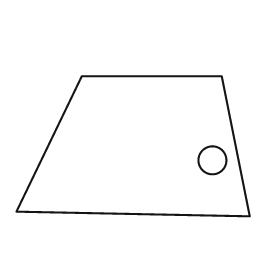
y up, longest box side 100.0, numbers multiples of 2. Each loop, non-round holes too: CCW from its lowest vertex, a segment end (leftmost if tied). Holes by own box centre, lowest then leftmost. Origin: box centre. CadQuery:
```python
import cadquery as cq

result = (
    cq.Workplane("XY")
    .moveTo(50.0, -30.0)
    .lineTo(38.0, 30.0)
    .lineTo(-22.0, 30.0)
    .lineTo(-50.0, -28.0)
    .close()
    .moveTo(34.0, -6.0)
    .circle(6.0)
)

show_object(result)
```